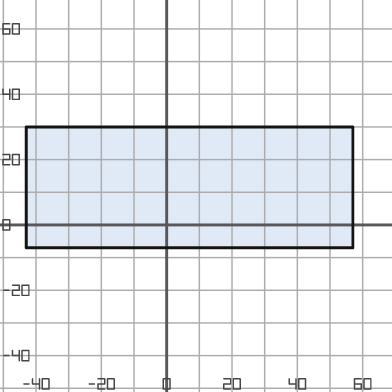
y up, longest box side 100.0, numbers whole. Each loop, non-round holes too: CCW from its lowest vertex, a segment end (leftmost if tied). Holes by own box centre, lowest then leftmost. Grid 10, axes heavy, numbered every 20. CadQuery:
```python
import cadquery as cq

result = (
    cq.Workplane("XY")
    .moveTo(-43.0, -7.0)
    .lineTo(57.0, -7.0)
    .lineTo(57.0, 30.0)
    .lineTo(-43.0, 30.0)
    .close()
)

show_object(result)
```